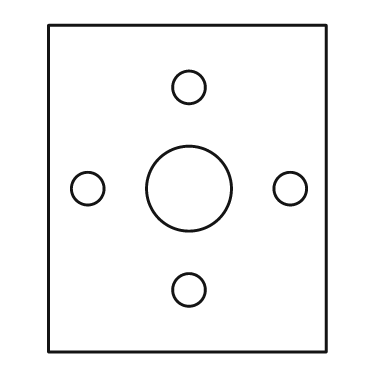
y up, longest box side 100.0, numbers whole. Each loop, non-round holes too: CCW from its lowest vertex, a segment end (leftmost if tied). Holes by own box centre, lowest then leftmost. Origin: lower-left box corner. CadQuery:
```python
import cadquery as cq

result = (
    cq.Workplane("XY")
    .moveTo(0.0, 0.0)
    .lineTo(85.0, 0.0)
    .lineTo(85.0, 100.0)
    .lineTo(0.0, 100.0)
    .close()
    .moveTo(43.0, 19.0)
    .circle(5.0)
    .moveTo(12.0, 50.0)
    .circle(5.0)
    .moveTo(43.0, 50.0)
    .circle(13.0)
    .moveTo(74.0, 50.0)
    .circle(5.0)
    .moveTo(43.0, 81.0)
    .circle(5.0)
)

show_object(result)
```